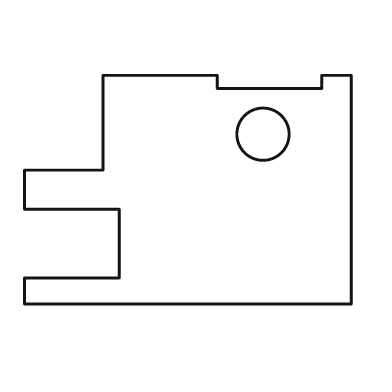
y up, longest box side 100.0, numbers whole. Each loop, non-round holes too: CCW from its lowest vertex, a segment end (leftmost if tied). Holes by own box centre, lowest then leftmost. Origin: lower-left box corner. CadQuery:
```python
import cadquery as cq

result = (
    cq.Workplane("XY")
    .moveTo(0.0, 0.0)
    .lineTo(100.0, 0.0)
    .lineTo(100.0, 70.0)
    .lineTo(91.0, 70.0)
    .lineTo(91.0, 66.0)
    .lineTo(59.0, 66.0)
    .lineTo(59.0, 70.0)
    .lineTo(24.0, 70.0)
    .lineTo(24.0, 41.0)
    .lineTo(0.0, 41.0)
    .lineTo(0.0, 29.0)
    .lineTo(29.0, 29.0)
    .lineTo(29.0, 8.0)
    .lineTo(0.0, 8.0)
    .close()
    .moveTo(73.0, 52.0)
    .circle(8.0)
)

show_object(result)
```